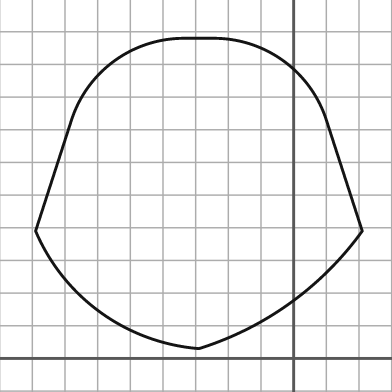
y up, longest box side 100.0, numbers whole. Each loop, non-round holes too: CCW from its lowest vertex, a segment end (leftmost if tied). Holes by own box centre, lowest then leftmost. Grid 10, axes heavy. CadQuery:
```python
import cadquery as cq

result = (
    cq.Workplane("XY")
    .moveTo(-29.0, 3.0)
    .threePointArc((-1.0, 17.0), (21.0, 39.0))
    .lineTo(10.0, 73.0)
    .threePointArc((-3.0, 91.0), (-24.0, 98.0))
    .lineTo(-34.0, 98.0)
    .threePointArc((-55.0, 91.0), (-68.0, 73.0))
    .lineTo(-79.0, 39.0)
    .threePointArc((-59.0, 14.0), (-29.0, 3.0))
    .close()
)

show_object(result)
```